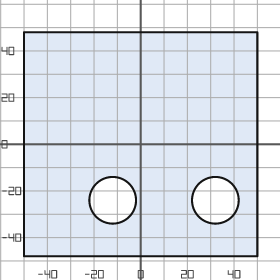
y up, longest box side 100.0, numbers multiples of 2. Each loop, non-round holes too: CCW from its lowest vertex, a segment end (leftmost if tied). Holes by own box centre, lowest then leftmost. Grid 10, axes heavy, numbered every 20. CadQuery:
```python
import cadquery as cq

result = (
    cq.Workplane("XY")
    .moveTo(-50.0, -48.0)
    .lineTo(50.0, -48.0)
    .lineTo(50.0, 48.0)
    .lineTo(-50.0, 48.0)
    .close()
    .moveTo(-12.0, -24.0)
    .circle(10.0)
    .moveTo(32.0, -24.0)
    .circle(10.0)
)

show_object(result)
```